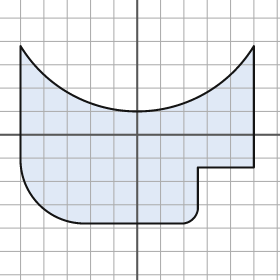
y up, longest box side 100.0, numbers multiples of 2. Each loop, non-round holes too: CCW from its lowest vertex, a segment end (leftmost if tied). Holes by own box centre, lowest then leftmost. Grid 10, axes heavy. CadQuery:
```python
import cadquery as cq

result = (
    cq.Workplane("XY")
    .moveTo(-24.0, -38.0)
    .lineTo(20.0, -38.0)
    .threePointArc((24.0, -36.0), (26.0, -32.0))
    .lineTo(26.0, -14.0)
    .lineTo(50.0, -14.0)
    .lineTo(50.0, 38.0)
    .threePointArc((0.0, 10.0), (-50.0, 38.0))
    .lineTo(-50.0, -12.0)
    .threePointArc((-42.0, -30.0), (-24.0, -38.0))
    .close()
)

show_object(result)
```